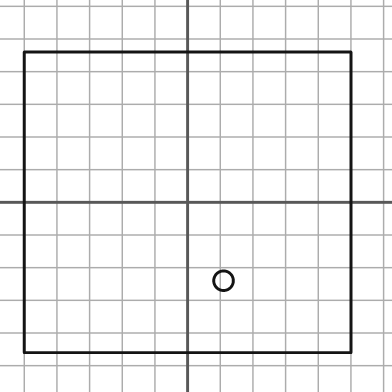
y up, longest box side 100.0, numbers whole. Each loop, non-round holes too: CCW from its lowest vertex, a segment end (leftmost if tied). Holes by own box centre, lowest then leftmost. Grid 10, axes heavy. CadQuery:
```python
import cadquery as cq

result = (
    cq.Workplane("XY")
    .moveTo(-50.0, -46.0)
    .lineTo(50.0, -46.0)
    .lineTo(50.0, 46.0)
    .lineTo(-50.0, 46.0)
    .close()
    .moveTo(11.0, -24.0)
    .circle(3.0)
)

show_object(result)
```